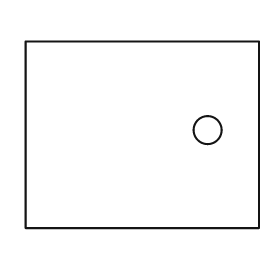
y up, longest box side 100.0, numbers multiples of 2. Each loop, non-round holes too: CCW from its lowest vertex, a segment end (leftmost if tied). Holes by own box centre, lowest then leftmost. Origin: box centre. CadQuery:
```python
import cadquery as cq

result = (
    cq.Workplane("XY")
    .moveTo(-50.0, -40.0)
    .lineTo(50.0, -40.0)
    .lineTo(50.0, 40.0)
    .lineTo(-50.0, 40.0)
    .close()
    .moveTo(28.0, 2.0)
    .circle(6.0)
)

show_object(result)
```